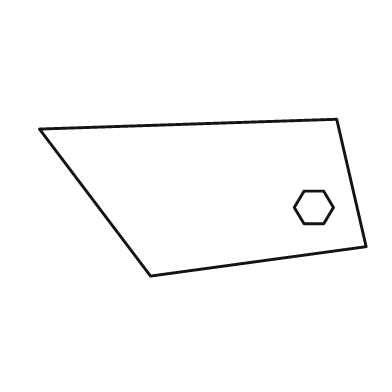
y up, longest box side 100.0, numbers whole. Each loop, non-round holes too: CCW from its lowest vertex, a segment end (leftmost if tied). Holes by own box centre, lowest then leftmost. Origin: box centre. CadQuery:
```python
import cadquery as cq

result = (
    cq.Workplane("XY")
    .moveTo(-16.0, -24.0)
    .lineTo(50.0, -15.0)
    .lineTo(41.0, 24.0)
    .lineTo(-50.0, 21.0)
    .close()
    .moveTo(31.0, -8.0)
    .lineTo(37.0, -8.0)
    .lineTo(40.0, -3.0)
    .lineTo(37.0, 2.0)
    .lineTo(31.0, 2.0)
    .lineTo(28.0, -3.0)
    .close()
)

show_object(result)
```